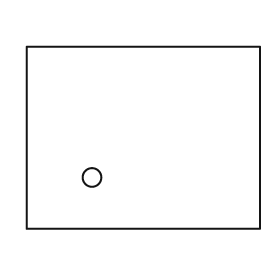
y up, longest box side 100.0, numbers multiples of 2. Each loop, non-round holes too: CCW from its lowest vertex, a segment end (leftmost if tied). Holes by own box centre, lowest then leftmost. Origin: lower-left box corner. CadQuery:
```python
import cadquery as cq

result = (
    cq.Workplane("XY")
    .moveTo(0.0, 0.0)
    .lineTo(100.0, 0.0)
    .lineTo(100.0, 78.0)
    .lineTo(0.0, 78.0)
    .close()
    .moveTo(28.0, 22.0)
    .circle(4.0)
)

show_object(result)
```